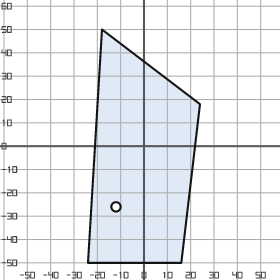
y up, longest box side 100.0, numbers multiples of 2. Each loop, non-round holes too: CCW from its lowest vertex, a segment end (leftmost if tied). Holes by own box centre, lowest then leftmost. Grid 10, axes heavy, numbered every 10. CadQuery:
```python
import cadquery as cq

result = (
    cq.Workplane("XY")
    .moveTo(-24.0, -50.0)
    .lineTo(16.0, -50.0)
    .lineTo(24.0, 18.0)
    .lineTo(-18.0, 50.0)
    .close()
    .moveTo(-12.0, -26.0)
    .circle(2.0)
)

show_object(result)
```